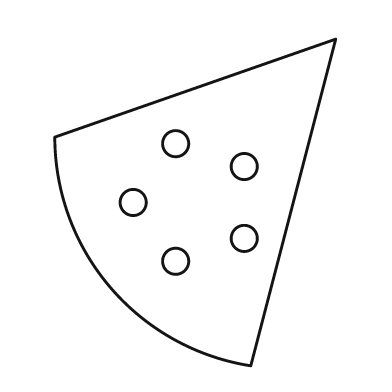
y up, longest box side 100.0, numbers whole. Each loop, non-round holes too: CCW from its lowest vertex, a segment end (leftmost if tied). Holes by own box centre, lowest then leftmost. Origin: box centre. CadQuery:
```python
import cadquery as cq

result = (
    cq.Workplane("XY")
    .moveTo(17.0, -50.0)
    .lineTo(43.0, 50.0)
    .lineTo(-43.0, 20.0)
    .threePointArc((-26.0, -26.0), (17.0, -50.0))
    .close()
    .moveTo(-6.0, -18.0)
    .circle(4.0)
    .moveTo(15.0, -11.0)
    .circle(4.0)
    .moveTo(-19.0, 0.0)
    .circle(4.0)
    .moveTo(15.0, 11.0)
    .circle(4.0)
    .moveTo(-6.0, 18.0)
    .circle(4.0)
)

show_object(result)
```